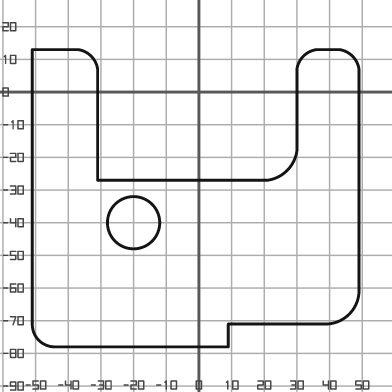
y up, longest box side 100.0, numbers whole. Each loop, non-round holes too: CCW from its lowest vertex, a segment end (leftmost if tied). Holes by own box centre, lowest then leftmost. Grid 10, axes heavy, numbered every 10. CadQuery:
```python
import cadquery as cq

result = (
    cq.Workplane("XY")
    .moveTo(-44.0, -78.0)
    .lineTo(9.0, -78.0)
    .lineTo(9.0, -71.0)
    .lineTo(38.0, -71.0)
    .threePointArc((46.0, -68.0), (49.0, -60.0))
    .lineTo(49.0, 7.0)
    .threePointArc((47.0, 11.0), (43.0, 13.0))
    .lineTo(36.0, 13.0)
    .threePointArc((32.0, 11.0), (30.0, 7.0))
    .lineTo(30.0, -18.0)
    .threePointArc((27.0, -24.0), (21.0, -27.0))
    .lineTo(-31.0, -27.0)
    .lineTo(-31.0, 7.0)
    .threePointArc((-33.0, 11.0), (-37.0, 13.0))
    .lineTo(-51.0, 13.0)
    .lineTo(-51.0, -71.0)
    .threePointArc((-49.0, -76.0), (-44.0, -78.0))
    .close()
    .moveTo(-20.0, -40.0)
    .circle(8.0)
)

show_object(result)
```